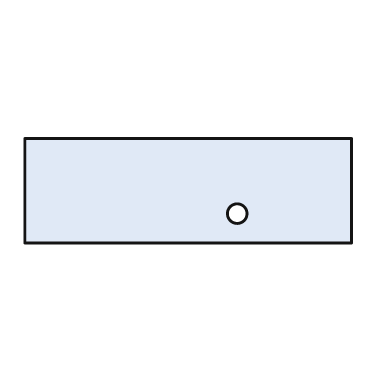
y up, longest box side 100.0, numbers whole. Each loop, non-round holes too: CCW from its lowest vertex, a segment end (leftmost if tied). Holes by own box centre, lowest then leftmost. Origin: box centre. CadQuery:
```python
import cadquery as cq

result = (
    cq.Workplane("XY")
    .moveTo(-50.0, -16.0)
    .lineTo(50.0, -16.0)
    .lineTo(50.0, 16.0)
    .lineTo(-50.0, 16.0)
    .close()
    .moveTo(15.0, -7.0)
    .circle(3.0)
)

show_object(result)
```